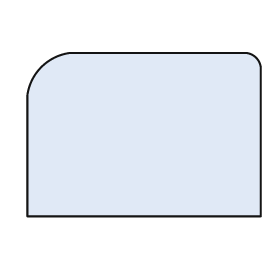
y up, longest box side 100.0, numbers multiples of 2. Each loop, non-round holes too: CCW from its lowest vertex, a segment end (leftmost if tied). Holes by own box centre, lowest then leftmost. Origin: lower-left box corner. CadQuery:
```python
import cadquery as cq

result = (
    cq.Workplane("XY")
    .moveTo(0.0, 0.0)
    .lineTo(100.0, 0.0)
    .lineTo(100.0, 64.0)
    .threePointArc((98.0, 68.0), (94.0, 70.0))
    .lineTo(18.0, 70.0)
    .threePointArc((6.0, 64.0), (0.0, 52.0))
    .close()
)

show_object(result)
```